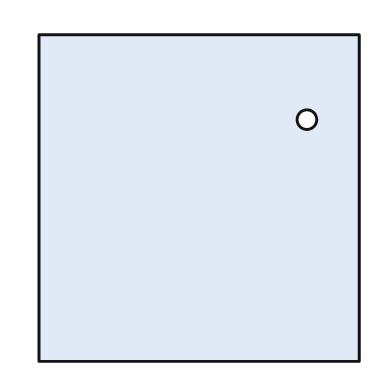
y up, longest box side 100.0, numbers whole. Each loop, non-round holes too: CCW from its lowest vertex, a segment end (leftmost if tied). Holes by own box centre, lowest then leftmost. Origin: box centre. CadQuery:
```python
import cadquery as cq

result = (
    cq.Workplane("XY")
    .moveTo(-49.0, -50.0)
    .lineTo(49.0, -50.0)
    .lineTo(49.0, 50.0)
    .lineTo(-49.0, 50.0)
    .close()
    .moveTo(33.0, 24.0)
    .circle(3.0)
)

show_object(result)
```